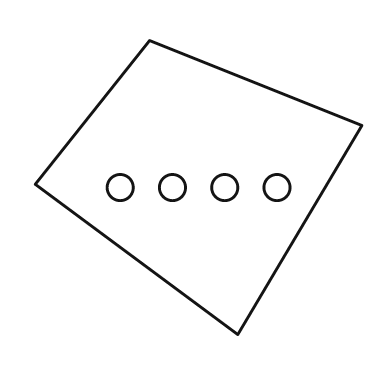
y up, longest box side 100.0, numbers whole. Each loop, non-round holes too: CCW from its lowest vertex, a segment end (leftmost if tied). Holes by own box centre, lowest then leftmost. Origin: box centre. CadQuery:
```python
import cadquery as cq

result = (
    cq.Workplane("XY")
    .moveTo(12.0, -45.0)
    .lineTo(50.0, 19.0)
    .lineTo(-15.0, 45.0)
    .lineTo(-50.0, 1.0)
    .close()
    .moveTo(-24.0, 0.0)
    .circle(4.0)
    .moveTo(-8.0, 0.0)
    .circle(4.0)
    .moveTo(8.0, 0.0)
    .circle(4.0)
    .moveTo(24.0, 0.0)
    .circle(4.0)
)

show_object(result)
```